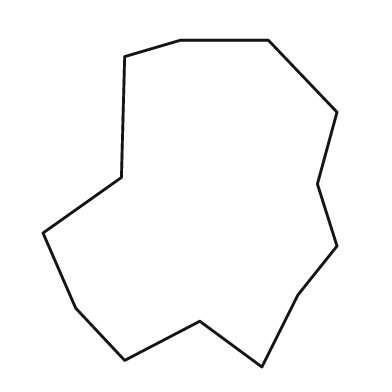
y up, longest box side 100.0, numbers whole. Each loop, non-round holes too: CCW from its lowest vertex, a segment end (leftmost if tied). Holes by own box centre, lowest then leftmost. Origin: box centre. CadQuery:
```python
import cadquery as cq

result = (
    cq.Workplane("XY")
    .moveTo(22.0, -50.0)
    .lineTo(33.0, -28.0)
    .lineTo(45.0, -13.0)
    .lineTo(39.0, 6.0)
    .lineTo(45.0, 28.0)
    .lineTo(24.0, 50.0)
    .lineTo(-3.0, 50.0)
    .lineTo(-20.0, 45.0)
    .lineTo(-21.0, 8.0)
    .lineTo(-45.0, -9.0)
    .lineTo(-35.0, -32.0)
    .lineTo(-20.0, -48.0)
    .lineTo(3.0, -36.0)
    .close()
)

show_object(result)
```